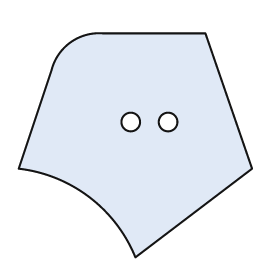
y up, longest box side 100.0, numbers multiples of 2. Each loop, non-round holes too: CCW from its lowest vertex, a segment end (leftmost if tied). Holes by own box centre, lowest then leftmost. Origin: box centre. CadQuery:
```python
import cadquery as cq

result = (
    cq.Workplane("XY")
    .moveTo(0.0, -48.0)
    .lineTo(50.0, -10.0)
    .lineTo(30.0, 48.0)
    .lineTo(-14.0, 48.0)
    .threePointArc((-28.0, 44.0), (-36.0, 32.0))
    .lineTo(-50.0, -10.0)
    .threePointArc((-20.0, -22.0), (0.0, -48.0))
    .close()
    .moveTo(-2.0, 10.0)
    .circle(4.0)
    .moveTo(14.0, 10.0)
    .circle(4.0)
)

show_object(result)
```